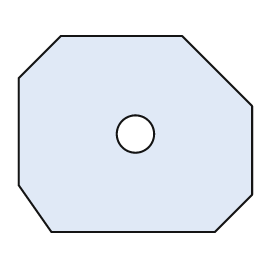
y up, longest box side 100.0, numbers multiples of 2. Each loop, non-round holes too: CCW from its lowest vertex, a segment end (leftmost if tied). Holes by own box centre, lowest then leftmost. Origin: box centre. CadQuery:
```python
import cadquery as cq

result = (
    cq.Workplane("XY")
    .moveTo(-36.0, -42.0)
    .lineTo(34.0, -42.0)
    .lineTo(50.0, -26.0)
    .lineTo(50.0, 12.0)
    .lineTo(20.0, 42.0)
    .lineTo(-32.0, 42.0)
    .lineTo(-50.0, 24.0)
    .lineTo(-50.0, -22.0)
    .close()
    .moveTo(0.0, 0.0)
    .circle(8.0)
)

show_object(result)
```